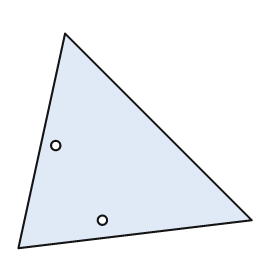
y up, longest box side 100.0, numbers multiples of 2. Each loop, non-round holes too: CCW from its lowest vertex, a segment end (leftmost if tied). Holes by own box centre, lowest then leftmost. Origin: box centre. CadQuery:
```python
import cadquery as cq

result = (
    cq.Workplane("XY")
    .moveTo(-50.0, -46.0)
    .lineTo(50.0, -34.0)
    .lineTo(-30.0, 46.0)
    .close()
    .moveTo(-14.0, -34.0)
    .circle(2.0)
    .moveTo(-34.0, -2.0)
    .circle(2.0)
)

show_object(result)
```